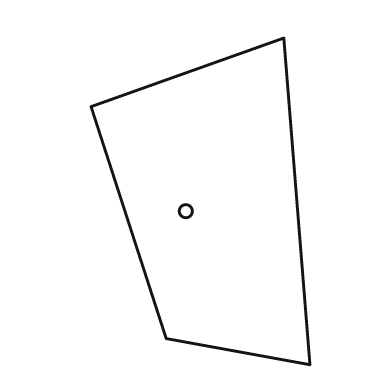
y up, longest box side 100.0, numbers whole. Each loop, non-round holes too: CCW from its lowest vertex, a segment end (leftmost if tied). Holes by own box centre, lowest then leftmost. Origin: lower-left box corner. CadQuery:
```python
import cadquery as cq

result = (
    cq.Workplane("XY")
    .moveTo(67.0, 0.0)
    .lineTo(59.0, 100.0)
    .lineTo(0.0, 79.0)
    .lineTo(23.0, 8.0)
    .close()
    .moveTo(29.0, 47.0)
    .circle(2.0)
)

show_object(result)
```